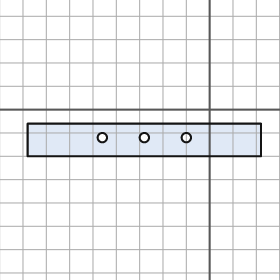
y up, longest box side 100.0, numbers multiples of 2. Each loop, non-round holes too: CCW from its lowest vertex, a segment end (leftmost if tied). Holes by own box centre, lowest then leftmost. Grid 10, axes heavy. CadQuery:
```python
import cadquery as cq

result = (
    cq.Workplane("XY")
    .moveTo(-78.0, -20.0)
    .lineTo(22.0, -20.0)
    .lineTo(22.0, -6.0)
    .lineTo(-78.0, -6.0)
    .close()
    .moveTo(-46.0, -12.0)
    .circle(2.0)
    .moveTo(-28.0, -12.0)
    .circle(2.0)
    .moveTo(-10.0, -12.0)
    .circle(2.0)
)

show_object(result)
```